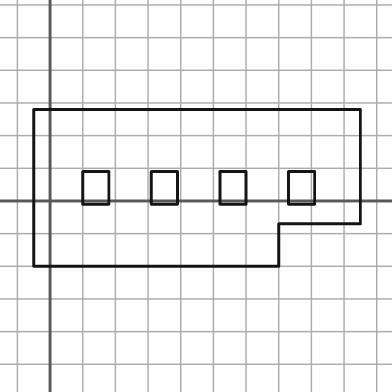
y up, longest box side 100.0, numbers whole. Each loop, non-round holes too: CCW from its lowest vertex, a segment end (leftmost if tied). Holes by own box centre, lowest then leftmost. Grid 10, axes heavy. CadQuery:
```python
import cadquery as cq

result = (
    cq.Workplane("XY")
    .moveTo(-5.0, -20.0)
    .lineTo(70.0, -20.0)
    .lineTo(70.0, -7.0)
    .lineTo(95.0, -7.0)
    .lineTo(95.0, 28.0)
    .lineTo(-5.0, 28.0)
    .close()
    .moveTo(10.0, -1.0)
    .lineTo(18.0, -1.0)
    .lineTo(18.0, 9.0)
    .lineTo(10.0, 9.0)
    .close()
    .moveTo(31.0, -1.0)
    .lineTo(39.0, -1.0)
    .lineTo(39.0, 9.0)
    .lineTo(31.0, 9.0)
    .close()
    .moveTo(52.0, -1.0)
    .lineTo(60.0, -1.0)
    .lineTo(60.0, 9.0)
    .lineTo(52.0, 9.0)
    .close()
    .moveTo(73.0, -1.0)
    .lineTo(81.0, -1.0)
    .lineTo(81.0, 9.0)
    .lineTo(73.0, 9.0)
    .close()
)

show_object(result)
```